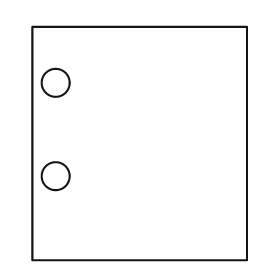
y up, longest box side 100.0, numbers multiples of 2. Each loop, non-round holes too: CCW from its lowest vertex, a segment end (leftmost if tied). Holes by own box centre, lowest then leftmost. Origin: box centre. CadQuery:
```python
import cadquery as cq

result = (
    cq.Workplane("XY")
    .moveTo(-46.0, -50.0)
    .lineTo(46.0, -50.0)
    .lineTo(46.0, 50.0)
    .lineTo(-46.0, 50.0)
    .close()
    .moveTo(-36.0, -14.0)
    .circle(6.0)
    .moveTo(-36.0, 26.0)
    .circle(6.0)
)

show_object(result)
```